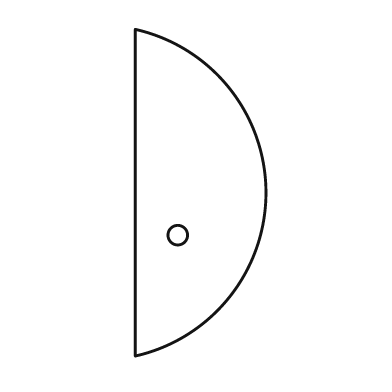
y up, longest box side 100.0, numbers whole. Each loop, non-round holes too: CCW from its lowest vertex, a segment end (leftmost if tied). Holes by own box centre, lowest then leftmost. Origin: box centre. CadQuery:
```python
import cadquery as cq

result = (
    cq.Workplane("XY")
    .moveTo(-20.0, -50.0)
    .threePointArc((20.0, 0.0), (-20.0, 50.0))
    .close()
    .moveTo(-7.0, -13.0)
    .circle(3.0)
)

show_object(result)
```